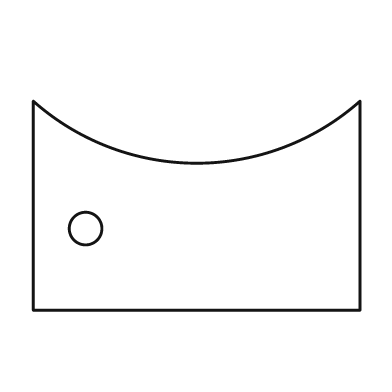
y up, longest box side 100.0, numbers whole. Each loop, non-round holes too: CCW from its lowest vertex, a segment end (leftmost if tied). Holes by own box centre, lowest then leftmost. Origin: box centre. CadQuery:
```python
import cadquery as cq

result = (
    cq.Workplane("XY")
    .moveTo(-50.0, -32.0)
    .lineTo(50.0, -32.0)
    .lineTo(50.0, 32.0)
    .threePointArc((0.0, 13.0), (-50.0, 32.0))
    .close()
    .moveTo(-34.0, -7.0)
    .circle(5.0)
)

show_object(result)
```